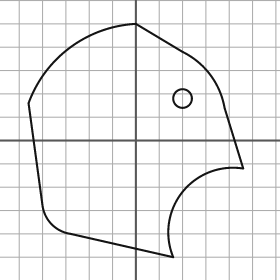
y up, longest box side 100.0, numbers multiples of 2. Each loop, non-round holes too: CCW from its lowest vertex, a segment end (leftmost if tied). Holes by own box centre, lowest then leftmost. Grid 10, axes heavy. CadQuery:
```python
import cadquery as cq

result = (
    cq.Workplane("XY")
    .moveTo(16.0, -50.0)
    .threePointArc((20.0, -22.0), (46.0, -12.0))
    .lineTo(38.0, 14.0)
    .threePointArc((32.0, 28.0), (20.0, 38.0))
    .lineTo(0.0, 50.0)
    .threePointArc((-28.0, 40.0), (-46.0, 16.0))
    .lineTo(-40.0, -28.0)
    .threePointArc((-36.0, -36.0), (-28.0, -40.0))
    .close()
    .moveTo(20.0, 18.0)
    .circle(4.0)
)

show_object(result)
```